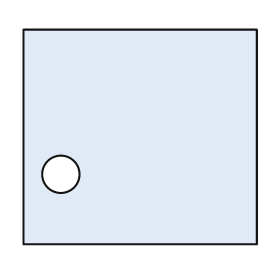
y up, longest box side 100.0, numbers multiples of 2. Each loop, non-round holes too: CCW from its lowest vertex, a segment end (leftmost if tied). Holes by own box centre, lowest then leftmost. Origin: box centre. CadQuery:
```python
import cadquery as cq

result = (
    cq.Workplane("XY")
    .moveTo(-50.0, -46.0)
    .lineTo(50.0, -46.0)
    .lineTo(50.0, 46.0)
    .lineTo(-50.0, 46.0)
    .close()
    .moveTo(-34.0, -16.0)
    .circle(8.0)
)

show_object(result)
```